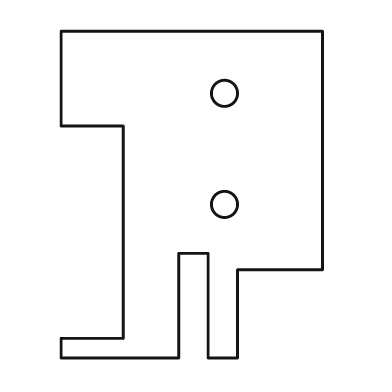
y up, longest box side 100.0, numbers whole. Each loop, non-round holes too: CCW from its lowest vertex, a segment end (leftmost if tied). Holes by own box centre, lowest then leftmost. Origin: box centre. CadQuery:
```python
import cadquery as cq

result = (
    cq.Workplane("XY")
    .moveTo(-40.0, -50.0)
    .lineTo(-4.0, -50.0)
    .lineTo(-4.0, -18.0)
    .lineTo(5.0, -18.0)
    .lineTo(5.0, -50.0)
    .lineTo(14.0, -50.0)
    .lineTo(14.0, -23.0)
    .lineTo(40.0, -23.0)
    .lineTo(40.0, 50.0)
    .lineTo(-40.0, 50.0)
    .lineTo(-40.0, 21.0)
    .lineTo(-21.0, 21.0)
    .lineTo(-21.0, -44.0)
    .lineTo(-40.0, -44.0)
    .close()
    .moveTo(10.0, -3.0)
    .circle(4.0)
    .moveTo(10.0, 31.0)
    .circle(4.0)
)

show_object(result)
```